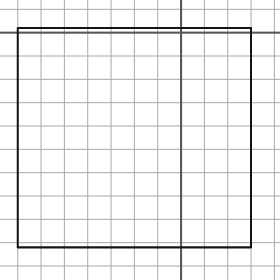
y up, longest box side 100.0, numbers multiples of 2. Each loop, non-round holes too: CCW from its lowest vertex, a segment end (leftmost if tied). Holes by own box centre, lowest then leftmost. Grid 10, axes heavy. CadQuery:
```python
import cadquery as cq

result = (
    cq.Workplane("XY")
    .moveTo(-70.0, -92.0)
    .lineTo(30.0, -92.0)
    .lineTo(30.0, 2.0)
    .lineTo(-70.0, 2.0)
    .close()
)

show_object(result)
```